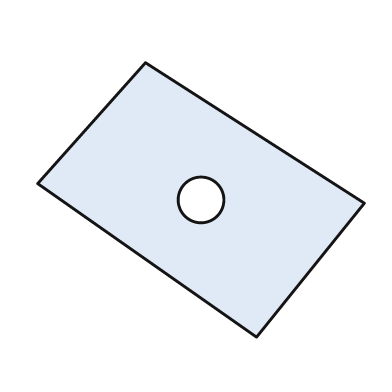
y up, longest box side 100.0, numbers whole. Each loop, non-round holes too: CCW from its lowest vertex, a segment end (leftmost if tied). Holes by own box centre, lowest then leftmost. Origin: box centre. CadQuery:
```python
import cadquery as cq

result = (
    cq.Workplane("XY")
    .moveTo(17.0, -42.0)
    .lineTo(50.0, -1.0)
    .lineTo(-17.0, 42.0)
    .lineTo(-50.0, 5.0)
    .close()
    .moveTo(0.0, 0.0)
    .circle(7.0)
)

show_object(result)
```